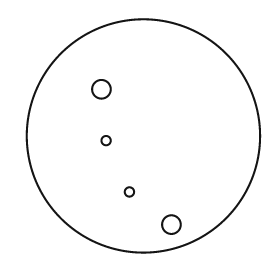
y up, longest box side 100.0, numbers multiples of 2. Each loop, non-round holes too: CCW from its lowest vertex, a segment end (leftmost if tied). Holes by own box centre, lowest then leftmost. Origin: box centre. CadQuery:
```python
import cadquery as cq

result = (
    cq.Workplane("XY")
    .moveTo(0.0, 0.0)
    .circle(50.0)
    .moveTo(12.0, -38.0)
    .circle(4.0)
    .moveTo(-6.0, -24.0)
    .circle(2.0)
    .moveTo(-16.0, -2.0)
    .circle(2.0)
    .moveTo(-18.0, 20.0)
    .circle(4.0)
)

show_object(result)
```